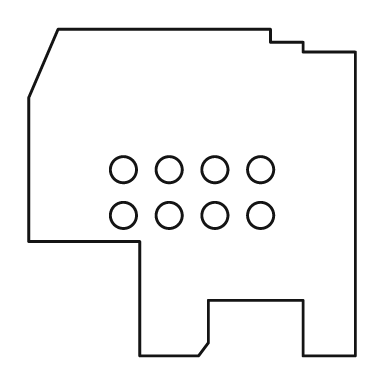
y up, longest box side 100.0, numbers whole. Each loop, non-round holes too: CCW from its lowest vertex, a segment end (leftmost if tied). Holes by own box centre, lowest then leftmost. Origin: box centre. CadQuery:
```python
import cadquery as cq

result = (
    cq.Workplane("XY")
    .moveTo(-16.0, -50.0)
    .lineTo(2.0, -50.0)
    .lineTo(5.0, -46.0)
    .lineTo(5.0, -33.0)
    .lineTo(34.0, -33.0)
    .lineTo(34.0, -50.0)
    .lineTo(50.0, -50.0)
    .lineTo(50.0, 43.0)
    .lineTo(34.0, 43.0)
    .lineTo(34.0, 46.0)
    .lineTo(24.0, 46.0)
    .lineTo(24.0, 50.0)
    .lineTo(-41.0, 50.0)
    .lineTo(-50.0, 29.0)
    .lineTo(-50.0, -15.0)
    .lineTo(-16.0, -15.0)
    .close()
    .moveTo(-21.0, -7.0)
    .circle(4.0)
    .moveTo(-7.0, -7.0)
    .circle(4.0)
    .moveTo(7.0, -7.0)
    .circle(4.0)
    .moveTo(21.0, -7.0)
    .circle(4.0)
    .moveTo(-21.0, 7.0)
    .circle(4.0)
    .moveTo(-7.0, 7.0)
    .circle(4.0)
    .moveTo(7.0, 7.0)
    .circle(4.0)
    .moveTo(21.0, 7.0)
    .circle(4.0)
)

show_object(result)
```